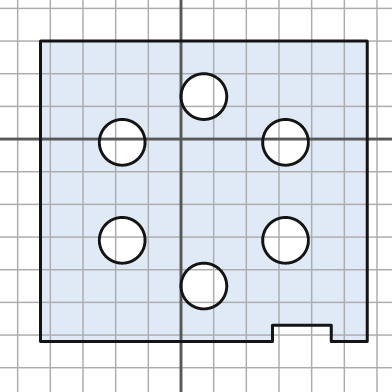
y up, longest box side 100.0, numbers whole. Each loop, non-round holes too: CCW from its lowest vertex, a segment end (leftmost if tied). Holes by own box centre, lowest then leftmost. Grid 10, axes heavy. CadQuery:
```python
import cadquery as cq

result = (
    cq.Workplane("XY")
    .moveTo(-43.0, -62.0)
    .lineTo(28.0, -62.0)
    .lineTo(28.0, -57.0)
    .lineTo(46.0, -57.0)
    .lineTo(46.0, -62.0)
    .lineTo(57.0, -62.0)
    .lineTo(57.0, 30.0)
    .lineTo(-43.0, 30.0)
    .close()
    .moveTo(7.0, -45.0)
    .circle(7.0)
    .moveTo(-18.0, -31.0)
    .circle(7.0)
    .moveTo(32.0, -31.0)
    .circle(7.0)
    .moveTo(-18.0, -1.0)
    .circle(7.0)
    .moveTo(32.0, -1.0)
    .circle(7.0)
    .moveTo(7.0, 13.0)
    .circle(7.0)
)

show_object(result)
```